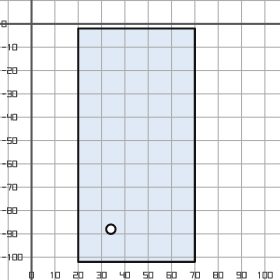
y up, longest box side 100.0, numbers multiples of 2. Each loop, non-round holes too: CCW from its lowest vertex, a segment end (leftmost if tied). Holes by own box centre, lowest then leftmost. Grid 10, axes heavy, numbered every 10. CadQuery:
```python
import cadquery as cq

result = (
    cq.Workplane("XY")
    .moveTo(20.0, -102.0)
    .lineTo(70.0, -102.0)
    .lineTo(70.0, -2.0)
    .lineTo(20.0, -2.0)
    .close()
    .moveTo(34.0, -88.0)
    .circle(2.0)
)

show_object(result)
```